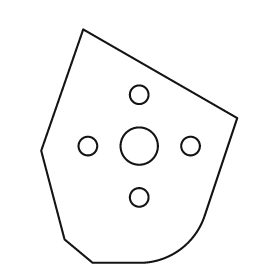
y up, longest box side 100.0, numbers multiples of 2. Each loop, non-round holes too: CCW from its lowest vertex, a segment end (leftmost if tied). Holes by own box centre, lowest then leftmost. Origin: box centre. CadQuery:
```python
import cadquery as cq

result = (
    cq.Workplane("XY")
    .moveTo(-20.0, -50.0)
    .lineTo(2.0, -50.0)
    .threePointArc((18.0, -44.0), (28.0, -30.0))
    .lineTo(42.0, 12.0)
    .lineTo(-24.0, 50.0)
    .lineTo(-42.0, -2.0)
    .lineTo(-32.0, -40.0)
    .close()
    .moveTo(0.0, -22.0)
    .circle(4.0)
    .moveTo(-22.0, 0.0)
    .circle(4.0)
    .moveTo(0.0, 0.0)
    .circle(8.0)
    .moveTo(22.0, 0.0)
    .circle(4.0)
    .moveTo(0.0, 22.0)
    .circle(4.0)
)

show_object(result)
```